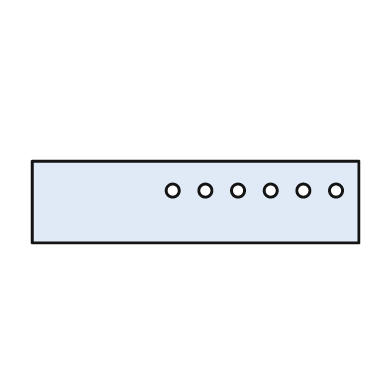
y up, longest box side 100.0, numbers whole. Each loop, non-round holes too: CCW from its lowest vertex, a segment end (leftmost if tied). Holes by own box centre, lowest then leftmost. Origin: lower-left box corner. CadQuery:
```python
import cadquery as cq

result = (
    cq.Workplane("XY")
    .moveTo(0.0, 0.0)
    .lineTo(100.0, 0.0)
    .lineTo(100.0, 25.0)
    .lineTo(0.0, 25.0)
    .close()
    .moveTo(43.0, 16.0)
    .circle(2.0)
    .moveTo(53.0, 16.0)
    .circle(2.0)
    .moveTo(63.0, 16.0)
    .circle(2.0)
    .moveTo(73.0, 16.0)
    .circle(2.0)
    .moveTo(83.0, 16.0)
    .circle(2.0)
    .moveTo(93.0, 16.0)
    .circle(2.0)
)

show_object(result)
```